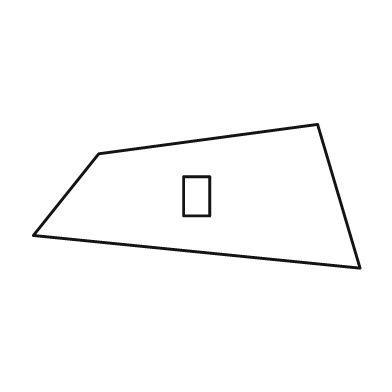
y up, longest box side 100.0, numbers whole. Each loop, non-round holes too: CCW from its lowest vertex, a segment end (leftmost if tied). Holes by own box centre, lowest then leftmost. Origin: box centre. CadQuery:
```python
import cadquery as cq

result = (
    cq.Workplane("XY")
    .moveTo(50.0, -22.0)
    .lineTo(37.0, 22.0)
    .lineTo(-30.0, 13.0)
    .lineTo(-50.0, -12.0)
    .close()
    .moveTo(-4.0, -6.0)
    .lineTo(4.0, -6.0)
    .lineTo(4.0, 6.0)
    .lineTo(-4.0, 6.0)
    .close()
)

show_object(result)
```